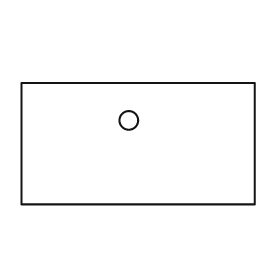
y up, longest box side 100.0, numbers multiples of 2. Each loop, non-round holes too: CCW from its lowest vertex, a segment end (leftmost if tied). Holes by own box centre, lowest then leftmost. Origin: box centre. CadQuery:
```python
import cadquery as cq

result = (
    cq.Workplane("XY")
    .moveTo(-50.0, -26.0)
    .lineTo(50.0, -26.0)
    .lineTo(50.0, 26.0)
    .lineTo(-50.0, 26.0)
    .close()
    .moveTo(-4.0, 10.0)
    .circle(4.0)
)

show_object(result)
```